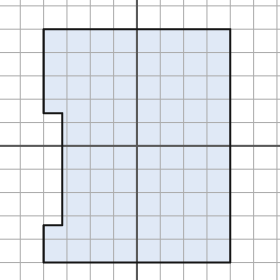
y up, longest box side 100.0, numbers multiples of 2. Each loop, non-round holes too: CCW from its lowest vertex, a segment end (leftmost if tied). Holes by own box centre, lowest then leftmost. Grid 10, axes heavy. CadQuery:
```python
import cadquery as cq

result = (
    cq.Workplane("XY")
    .moveTo(-40.0, -50.0)
    .lineTo(40.0, -50.0)
    .lineTo(40.0, 50.0)
    .lineTo(-40.0, 50.0)
    .lineTo(-40.0, 14.0)
    .lineTo(-32.0, 14.0)
    .lineTo(-32.0, -34.0)
    .lineTo(-40.0, -34.0)
    .close()
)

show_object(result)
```